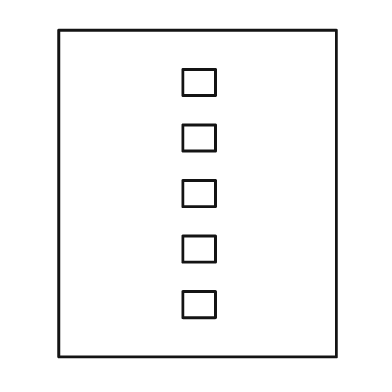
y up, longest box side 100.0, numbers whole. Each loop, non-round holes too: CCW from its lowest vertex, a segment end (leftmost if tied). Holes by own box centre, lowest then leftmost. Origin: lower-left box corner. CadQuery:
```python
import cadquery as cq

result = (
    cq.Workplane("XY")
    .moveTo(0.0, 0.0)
    .lineTo(85.0, 0.0)
    .lineTo(85.0, 100.0)
    .lineTo(0.0, 100.0)
    .close()
    .moveTo(38.0, 12.0)
    .lineTo(48.0, 12.0)
    .lineTo(48.0, 20.0)
    .lineTo(38.0, 20.0)
    .close()
    .moveTo(38.0, 29.0)
    .lineTo(48.0, 29.0)
    .lineTo(48.0, 37.0)
    .lineTo(38.0, 37.0)
    .close()
    .moveTo(38.0, 46.0)
    .lineTo(48.0, 46.0)
    .lineTo(48.0, 54.0)
    .lineTo(38.0, 54.0)
    .close()
    .moveTo(38.0, 63.0)
    .lineTo(48.0, 63.0)
    .lineTo(48.0, 71.0)
    .lineTo(38.0, 71.0)
    .close()
    .moveTo(38.0, 80.0)
    .lineTo(48.0, 80.0)
    .lineTo(48.0, 88.0)
    .lineTo(38.0, 88.0)
    .close()
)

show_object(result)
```